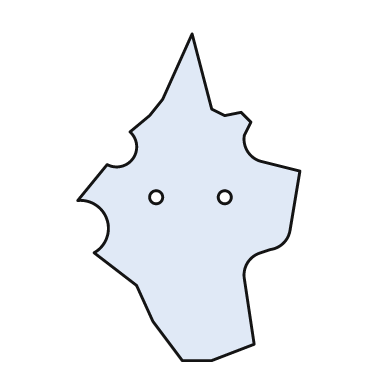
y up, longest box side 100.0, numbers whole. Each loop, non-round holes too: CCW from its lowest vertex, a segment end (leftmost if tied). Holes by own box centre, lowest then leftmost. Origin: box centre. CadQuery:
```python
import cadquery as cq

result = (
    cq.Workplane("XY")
    .moveTo(-2.0, -50.0)
    .lineTo(7.0, -50.0)
    .lineTo(20.0, -45.0)
    .lineTo(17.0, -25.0)
    .threePointArc((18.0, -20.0), (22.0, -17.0))
    .lineTo(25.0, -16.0)
    .threePointArc((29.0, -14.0), (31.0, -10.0))
    .lineTo(34.0, 8.0)
    .lineTo(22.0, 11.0)
    .threePointArc((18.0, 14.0), (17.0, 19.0))
    .lineTo(19.0, 23.0)
    .lineTo(16.0, 26.0)
    .lineTo(11.0, 25.0)
    .lineTo(7.0, 27.0)
    .lineTo(1.0, 50.0)
    .lineTo(-8.0, 30.0)
    .lineTo(-12.0, 25.0)
    .lineTo(-18.0, 20.0)
    .threePointArc((-17.0, 12.0), (-25.0, 10.0))
    .lineTo(-34.0, -1.0)
    .threePointArc((-25.0, -7.0), (-29.0, -17.0))
    .lineTo(-16.0, -27.0)
    .lineTo(-11.0, -38.0)
    .close()
    .moveTo(-10.0, 0.0)
    .circle(2.0)
    .moveTo(11.0, 0.0)
    .circle(2.0)
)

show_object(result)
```